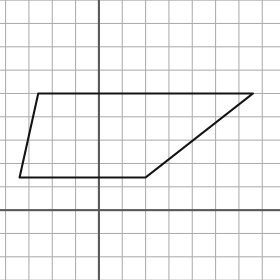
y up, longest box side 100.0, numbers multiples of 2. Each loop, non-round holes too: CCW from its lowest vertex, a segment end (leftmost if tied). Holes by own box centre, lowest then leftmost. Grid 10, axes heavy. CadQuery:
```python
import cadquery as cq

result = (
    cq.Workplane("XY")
    .moveTo(-34.0, 14.0)
    .lineTo(20.0, 14.0)
    .lineTo(66.0, 50.0)
    .lineTo(-26.0, 50.0)
    .close()
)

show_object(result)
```